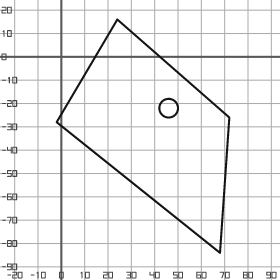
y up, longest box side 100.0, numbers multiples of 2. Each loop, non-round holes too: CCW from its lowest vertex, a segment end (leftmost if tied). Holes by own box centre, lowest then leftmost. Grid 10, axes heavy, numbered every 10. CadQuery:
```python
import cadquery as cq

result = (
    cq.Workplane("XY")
    .moveTo(68.0, -84.0)
    .lineTo(72.0, -26.0)
    .lineTo(24.0, 16.0)
    .lineTo(-2.0, -28.0)
    .close()
    .moveTo(46.0, -22.0)
    .circle(4.0)
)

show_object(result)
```